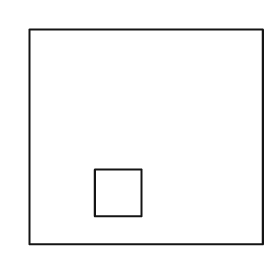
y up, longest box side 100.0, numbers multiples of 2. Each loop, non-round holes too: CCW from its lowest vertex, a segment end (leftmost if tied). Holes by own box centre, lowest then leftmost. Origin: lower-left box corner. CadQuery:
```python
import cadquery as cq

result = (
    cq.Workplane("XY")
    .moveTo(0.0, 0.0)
    .lineTo(100.0, 0.0)
    .lineTo(100.0, 92.0)
    .lineTo(0.0, 92.0)
    .close()
    .moveTo(28.0, 12.0)
    .lineTo(48.0, 12.0)
    .lineTo(48.0, 32.0)
    .lineTo(28.0, 32.0)
    .close()
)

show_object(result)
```